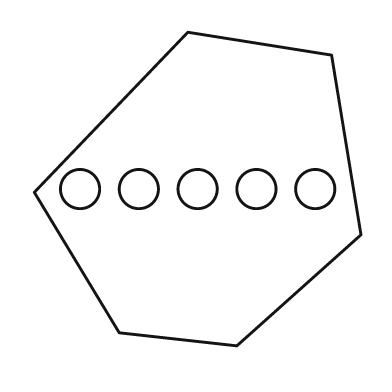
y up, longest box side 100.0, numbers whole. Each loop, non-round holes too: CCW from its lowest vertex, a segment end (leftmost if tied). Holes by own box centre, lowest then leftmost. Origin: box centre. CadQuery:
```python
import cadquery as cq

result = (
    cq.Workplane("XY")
    .moveTo(12.0, -48.0)
    .lineTo(50.0, -14.0)
    .lineTo(41.0, 41.0)
    .lineTo(-3.0, 48.0)
    .lineTo(-50.0, -1.0)
    .lineTo(-24.0, -44.0)
    .close()
    .moveTo(-36.0, 0.0)
    .circle(6.0)
    .moveTo(-18.0, 0.0)
    .circle(6.0)
    .moveTo(0.0, 0.0)
    .circle(6.0)
    .moveTo(18.0, 0.0)
    .circle(6.0)
    .moveTo(36.0, 0.0)
    .circle(6.0)
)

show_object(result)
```